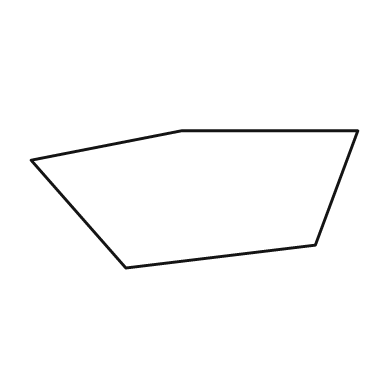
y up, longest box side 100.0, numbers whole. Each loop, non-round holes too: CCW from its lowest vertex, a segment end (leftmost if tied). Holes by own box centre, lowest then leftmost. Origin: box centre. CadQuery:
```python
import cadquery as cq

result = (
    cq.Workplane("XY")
    .moveTo(-21.0, -21.0)
    .lineTo(37.0, -14.0)
    .lineTo(50.0, 21.0)
    .lineTo(-4.0, 21.0)
    .lineTo(-50.0, 12.0)
    .close()
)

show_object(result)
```